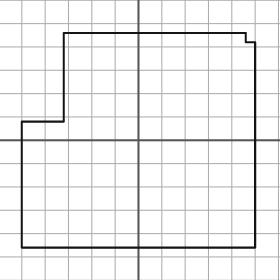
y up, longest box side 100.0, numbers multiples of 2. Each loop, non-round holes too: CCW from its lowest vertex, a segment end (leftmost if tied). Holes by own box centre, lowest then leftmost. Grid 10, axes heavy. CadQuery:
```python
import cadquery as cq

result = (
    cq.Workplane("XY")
    .moveTo(-50.0, -46.0)
    .lineTo(50.0, -46.0)
    .lineTo(50.0, 42.0)
    .lineTo(46.0, 42.0)
    .lineTo(46.0, 46.0)
    .lineTo(-32.0, 46.0)
    .lineTo(-32.0, 8.0)
    .lineTo(-50.0, 8.0)
    .close()
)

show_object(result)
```